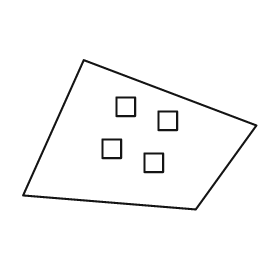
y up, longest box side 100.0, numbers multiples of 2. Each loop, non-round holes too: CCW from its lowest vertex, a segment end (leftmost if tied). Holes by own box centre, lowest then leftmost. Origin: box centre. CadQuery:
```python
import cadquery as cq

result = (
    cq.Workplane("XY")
    .moveTo(24.0, -32.0)
    .lineTo(50.0, 4.0)
    .lineTo(-24.0, 32.0)
    .lineTo(-50.0, -26.0)
    .close()
    .moveTo(2.0, -16.0)
    .lineTo(10.0, -16.0)
    .lineTo(10.0, -8.0)
    .lineTo(2.0, -8.0)
    .close()
    .moveTo(-16.0, -10.0)
    .lineTo(-8.0, -10.0)
    .lineTo(-8.0, -2.0)
    .lineTo(-16.0, -2.0)
    .close()
    .moveTo(8.0, 2.0)
    .lineTo(16.0, 2.0)
    .lineTo(16.0, 10.0)
    .lineTo(8.0, 10.0)
    .close()
    .moveTo(-10.0, 8.0)
    .lineTo(-2.0, 8.0)
    .lineTo(-2.0, 16.0)
    .lineTo(-10.0, 16.0)
    .close()
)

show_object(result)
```